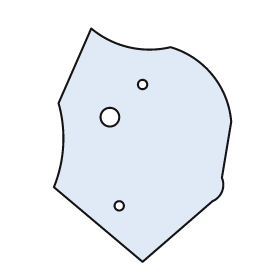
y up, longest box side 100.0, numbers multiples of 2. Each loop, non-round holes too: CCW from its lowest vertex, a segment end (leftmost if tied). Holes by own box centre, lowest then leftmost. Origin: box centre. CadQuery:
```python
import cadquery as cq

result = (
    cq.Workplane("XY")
    .moveTo(0.0, -50.0)
    .lineTo(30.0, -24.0)
    .threePointArc((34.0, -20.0), (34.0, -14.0))
    .lineTo(38.0, 10.0)
    .threePointArc((30.0, 30.0), (12.0, 42.0))
    .threePointArc((-6.0, 42.0), (-22.0, 50.0))
    .lineTo(-36.0, 18.0)
    .threePointArc((-34.0, 0.0), (-38.0, -18.0))
    .close()
    .moveTo(-10.0, -26.0)
    .circle(2.0)
    .moveTo(-14.0, 12.0)
    .circle(4.0)
    .moveTo(0.0, 26.0)
    .circle(2.0)
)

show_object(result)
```